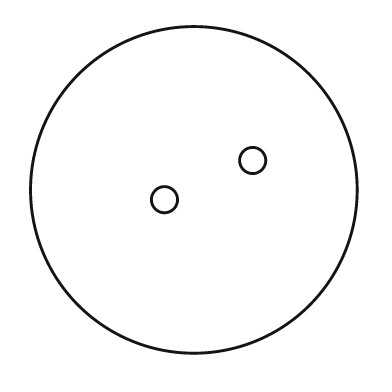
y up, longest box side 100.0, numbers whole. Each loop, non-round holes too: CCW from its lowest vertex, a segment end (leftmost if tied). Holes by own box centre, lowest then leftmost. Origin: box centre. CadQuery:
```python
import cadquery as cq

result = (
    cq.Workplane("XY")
    .moveTo(0.0, 0.0)
    .circle(50.0)
    .moveTo(-9.0, -3.0)
    .circle(4.0)
    .moveTo(18.0, 9.0)
    .circle(4.0)
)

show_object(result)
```